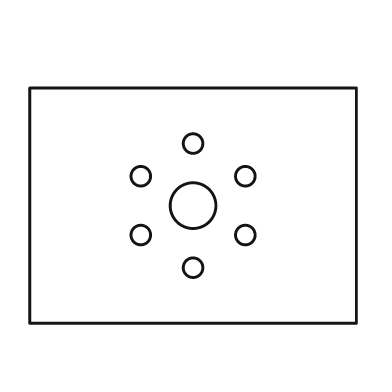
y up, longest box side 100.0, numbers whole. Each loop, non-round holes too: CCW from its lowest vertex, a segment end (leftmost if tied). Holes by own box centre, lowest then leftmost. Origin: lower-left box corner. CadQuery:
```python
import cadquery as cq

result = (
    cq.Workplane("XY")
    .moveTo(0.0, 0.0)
    .lineTo(100.0, 0.0)
    .lineTo(100.0, 72.0)
    .lineTo(0.0, 72.0)
    .close()
    .moveTo(50.0, 17.0)
    .circle(3.0)
    .moveTo(34.0, 27.0)
    .circle(3.0)
    .moveTo(66.0, 27.0)
    .circle(3.0)
    .moveTo(50.0, 36.0)
    .circle(7.0)
    .moveTo(34.0, 45.0)
    .circle(3.0)
    .moveTo(66.0, 45.0)
    .circle(3.0)
    .moveTo(50.0, 55.0)
    .circle(3.0)
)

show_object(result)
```